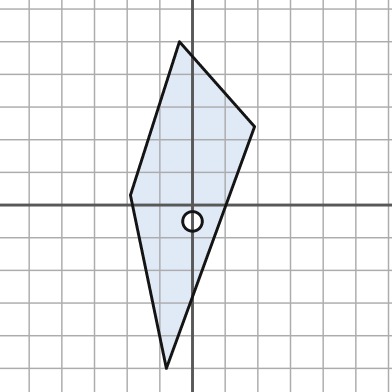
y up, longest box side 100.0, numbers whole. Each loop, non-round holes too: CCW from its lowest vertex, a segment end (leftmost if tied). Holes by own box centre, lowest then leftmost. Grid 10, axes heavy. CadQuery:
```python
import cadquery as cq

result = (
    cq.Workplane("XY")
    .moveTo(-8.0, -50.0)
    .lineTo(19.0, 24.0)
    .lineTo(-4.0, 50.0)
    .lineTo(-19.0, 3.0)
    .close()
    .moveTo(0.0, -5.0)
    .circle(3.0)
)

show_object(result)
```